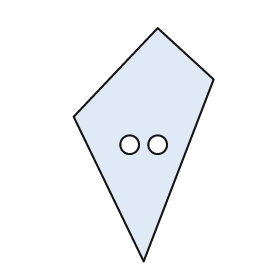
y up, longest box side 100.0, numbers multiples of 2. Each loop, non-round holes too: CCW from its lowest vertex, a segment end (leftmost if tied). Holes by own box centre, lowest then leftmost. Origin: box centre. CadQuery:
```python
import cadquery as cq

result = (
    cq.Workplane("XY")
    .moveTo(0.0, -50.0)
    .lineTo(30.0, 28.0)
    .lineTo(6.0, 50.0)
    .lineTo(-30.0, 12.0)
    .close()
    .moveTo(-6.0, 0.0)
    .circle(4.0)
    .moveTo(6.0, 0.0)
    .circle(4.0)
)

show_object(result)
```